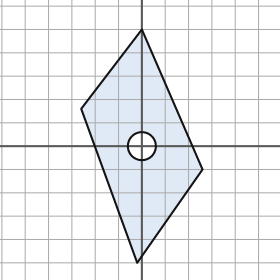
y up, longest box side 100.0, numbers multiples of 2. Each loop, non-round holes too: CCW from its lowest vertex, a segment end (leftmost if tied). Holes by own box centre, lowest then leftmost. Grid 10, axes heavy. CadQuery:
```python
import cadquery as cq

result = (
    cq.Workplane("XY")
    .moveTo(-2.0, -50.0)
    .lineTo(26.0, -10.0)
    .lineTo(0.0, 50.0)
    .lineTo(-26.0, 16.0)
    .close()
    .moveTo(0.0, 0.0)
    .circle(6.0)
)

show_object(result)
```